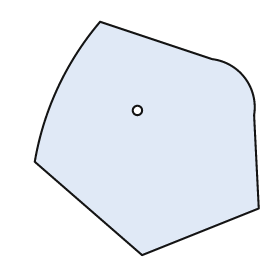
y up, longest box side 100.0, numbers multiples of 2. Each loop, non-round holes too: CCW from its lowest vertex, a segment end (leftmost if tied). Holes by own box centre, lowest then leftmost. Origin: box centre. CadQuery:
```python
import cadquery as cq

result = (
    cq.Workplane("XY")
    .moveTo(-2.0, -50.0)
    .lineTo(48.0, -30.0)
    .lineTo(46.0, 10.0)
    .threePointArc((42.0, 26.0), (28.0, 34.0))
    .lineTo(-20.0, 50.0)
    .threePointArc((-38.0, 22.0), (-48.0, -10.0))
    .close()
    .moveTo(-4.0, 12.0)
    .circle(2.0)
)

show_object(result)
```